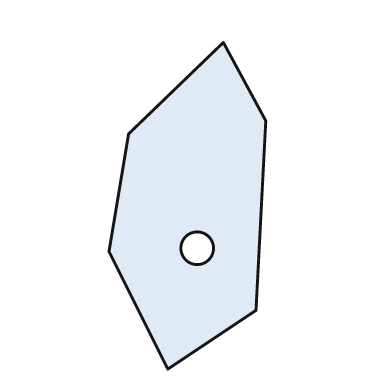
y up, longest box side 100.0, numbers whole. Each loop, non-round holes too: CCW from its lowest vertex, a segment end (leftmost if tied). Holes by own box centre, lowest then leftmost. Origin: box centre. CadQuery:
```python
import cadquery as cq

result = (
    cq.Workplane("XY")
    .moveTo(-6.0, -50.0)
    .lineTo(21.0, -32.0)
    .lineTo(24.0, 26.0)
    .lineTo(11.0, 50.0)
    .lineTo(-18.0, 22.0)
    .lineTo(-24.0, -14.0)
    .close()
    .moveTo(3.0, -13.0)
    .circle(5.0)
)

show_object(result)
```